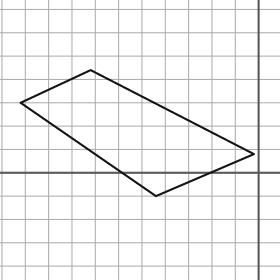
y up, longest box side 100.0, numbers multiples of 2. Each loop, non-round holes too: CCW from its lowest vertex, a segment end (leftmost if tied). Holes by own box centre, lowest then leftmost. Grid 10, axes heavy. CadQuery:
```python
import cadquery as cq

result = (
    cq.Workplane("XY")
    .moveTo(-44.0, -10.0)
    .lineTo(-2.0, 8.0)
    .lineTo(-72.0, 44.0)
    .lineTo(-102.0, 30.0)
    .close()
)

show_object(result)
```